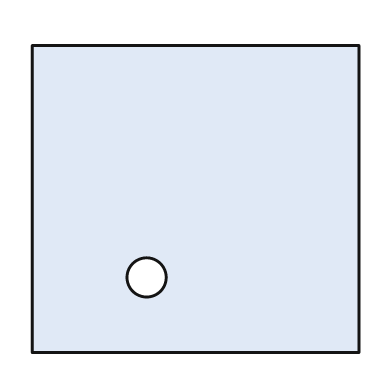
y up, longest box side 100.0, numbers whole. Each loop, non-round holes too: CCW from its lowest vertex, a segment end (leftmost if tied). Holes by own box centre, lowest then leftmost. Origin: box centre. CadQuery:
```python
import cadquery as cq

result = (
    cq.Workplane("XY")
    .moveTo(-50.0, -47.0)
    .lineTo(50.0, -47.0)
    .lineTo(50.0, 47.0)
    .lineTo(-50.0, 47.0)
    .close()
    .moveTo(-15.0, -24.0)
    .circle(6.0)
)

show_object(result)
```